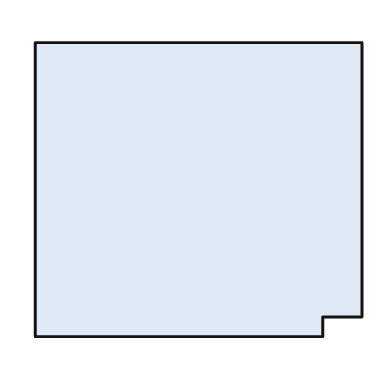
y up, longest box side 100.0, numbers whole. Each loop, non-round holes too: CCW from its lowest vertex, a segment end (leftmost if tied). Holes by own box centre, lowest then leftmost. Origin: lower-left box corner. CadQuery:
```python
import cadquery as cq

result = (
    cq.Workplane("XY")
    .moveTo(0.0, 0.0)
    .lineTo(88.0, 0.0)
    .lineTo(88.0, 6.0)
    .lineTo(100.0, 6.0)
    .lineTo(100.0, 90.0)
    .lineTo(0.0, 90.0)
    .close()
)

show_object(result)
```